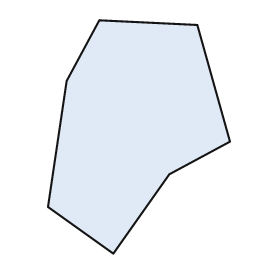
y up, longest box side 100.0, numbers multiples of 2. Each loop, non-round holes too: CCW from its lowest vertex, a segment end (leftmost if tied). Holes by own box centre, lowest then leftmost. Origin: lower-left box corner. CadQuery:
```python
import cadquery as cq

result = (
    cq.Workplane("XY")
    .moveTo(28.0, 0.0)
    .lineTo(52.0, 34.0)
    .lineTo(78.0, 48.0)
    .lineTo(64.0, 98.0)
    .lineTo(22.0, 100.0)
    .lineTo(8.0, 74.0)
    .lineTo(0.0, 20.0)
    .close()
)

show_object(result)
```